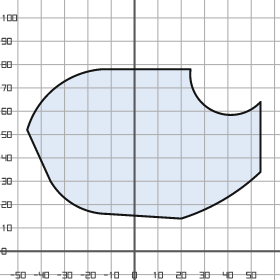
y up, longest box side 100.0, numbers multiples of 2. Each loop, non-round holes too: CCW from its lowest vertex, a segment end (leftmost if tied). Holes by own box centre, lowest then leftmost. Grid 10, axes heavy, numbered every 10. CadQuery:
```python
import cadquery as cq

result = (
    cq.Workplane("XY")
    .moveTo(20.0, 14.0)
    .threePointArc((38.0, 22.0), (54.0, 34.0))
    .lineTo(54.0, 64.0)
    .threePointArc((34.0, 60.0), (24.0, 78.0))
    .lineTo(-14.0, 78.0)
    .threePointArc((-34.0, 70.0), (-46.0, 52.0))
    .lineTo(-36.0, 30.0)
    .threePointArc((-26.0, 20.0), (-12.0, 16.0))
    .close()
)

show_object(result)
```